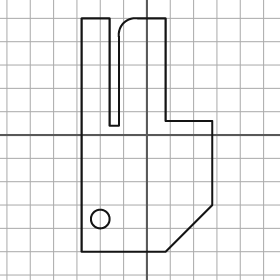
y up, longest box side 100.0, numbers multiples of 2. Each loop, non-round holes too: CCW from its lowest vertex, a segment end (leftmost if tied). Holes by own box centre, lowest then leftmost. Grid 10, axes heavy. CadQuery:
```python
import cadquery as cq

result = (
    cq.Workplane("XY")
    .moveTo(-28.0, -50.0)
    .lineTo(8.0, -50.0)
    .lineTo(28.0, -30.0)
    .lineTo(28.0, 6.0)
    .lineTo(8.0, 6.0)
    .lineTo(8.0, 50.0)
    .lineTo(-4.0, 50.0)
    .threePointArc((-10.0, 48.0), (-12.0, 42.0))
    .lineTo(-12.0, 4.0)
    .lineTo(-16.0, 4.0)
    .lineTo(-16.0, 50.0)
    .lineTo(-28.0, 50.0)
    .close()
    .moveTo(-20.0, -36.0)
    .circle(4.0)
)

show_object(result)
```